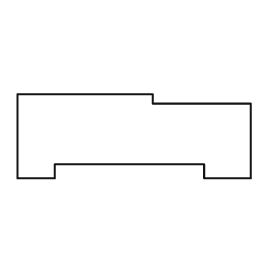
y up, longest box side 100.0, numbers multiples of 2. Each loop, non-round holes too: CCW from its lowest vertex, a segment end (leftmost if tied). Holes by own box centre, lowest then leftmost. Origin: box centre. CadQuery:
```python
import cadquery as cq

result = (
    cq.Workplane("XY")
    .moveTo(-50.0, -18.0)
    .lineTo(-34.0, -18.0)
    .lineTo(-34.0, -12.0)
    .lineTo(30.0, -12.0)
    .lineTo(30.0, -18.0)
    .lineTo(50.0, -18.0)
    .lineTo(50.0, 14.0)
    .lineTo(8.0, 14.0)
    .lineTo(8.0, 18.0)
    .lineTo(-50.0, 18.0)
    .close()
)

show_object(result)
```